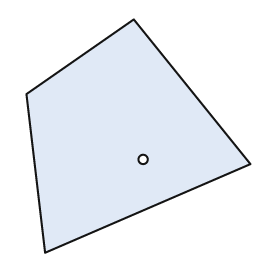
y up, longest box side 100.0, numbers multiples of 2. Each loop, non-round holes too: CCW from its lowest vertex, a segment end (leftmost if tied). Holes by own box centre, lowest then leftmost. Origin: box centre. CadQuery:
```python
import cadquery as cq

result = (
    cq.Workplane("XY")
    .moveTo(-40.0, -50.0)
    .lineTo(48.0, -12.0)
    .lineTo(-2.0, 50.0)
    .lineTo(-48.0, 18.0)
    .close()
    .moveTo(2.0, -10.0)
    .circle(2.0)
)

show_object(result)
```